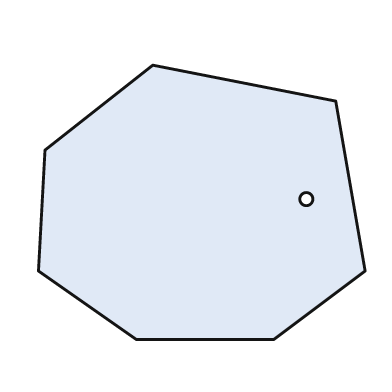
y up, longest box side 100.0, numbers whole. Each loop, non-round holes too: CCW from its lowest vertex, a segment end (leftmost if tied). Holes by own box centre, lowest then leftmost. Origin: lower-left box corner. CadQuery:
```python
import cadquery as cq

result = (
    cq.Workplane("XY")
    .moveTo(30.0, 0.0)
    .lineTo(72.0, 0.0)
    .lineTo(100.0, 21.0)
    .lineTo(91.0, 73.0)
    .lineTo(35.0, 84.0)
    .lineTo(2.0, 58.0)
    .lineTo(0.0, 21.0)
    .close()
    .moveTo(82.0, 43.0)
    .circle(2.0)
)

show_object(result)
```